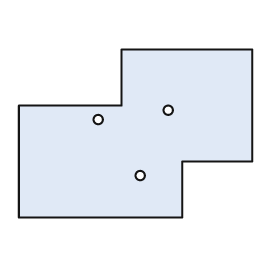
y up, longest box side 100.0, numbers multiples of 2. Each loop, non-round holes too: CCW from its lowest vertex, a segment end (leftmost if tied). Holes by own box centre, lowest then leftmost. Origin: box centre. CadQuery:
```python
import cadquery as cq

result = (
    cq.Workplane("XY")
    .moveTo(-50.0, -36.0)
    .lineTo(20.0, -36.0)
    .lineTo(20.0, -12.0)
    .lineTo(50.0, -12.0)
    .lineTo(50.0, 36.0)
    .lineTo(-6.0, 36.0)
    .lineTo(-6.0, 12.0)
    .lineTo(-50.0, 12.0)
    .close()
    .moveTo(2.0, -18.0)
    .circle(2.0)
    .moveTo(-16.0, 6.0)
    .circle(2.0)
    .moveTo(14.0, 10.0)
    .circle(2.0)
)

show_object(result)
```